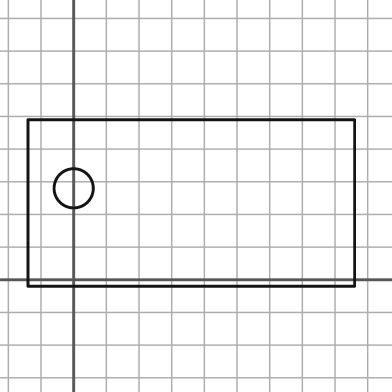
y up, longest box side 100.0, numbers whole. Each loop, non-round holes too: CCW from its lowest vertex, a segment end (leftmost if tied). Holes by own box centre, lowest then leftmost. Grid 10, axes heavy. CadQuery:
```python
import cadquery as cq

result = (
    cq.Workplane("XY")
    .moveTo(-14.0, -2.0)
    .lineTo(86.0, -2.0)
    .lineTo(86.0, 49.0)
    .lineTo(-14.0, 49.0)
    .close()
    .moveTo(0.0, 28.0)
    .circle(6.0)
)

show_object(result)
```